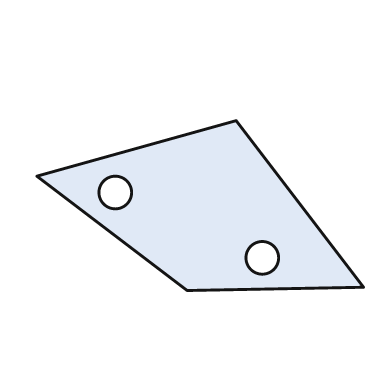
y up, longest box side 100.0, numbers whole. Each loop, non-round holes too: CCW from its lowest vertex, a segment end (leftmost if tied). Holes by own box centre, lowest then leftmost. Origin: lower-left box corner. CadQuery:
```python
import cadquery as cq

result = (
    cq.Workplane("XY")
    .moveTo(46.0, 0.0)
    .lineTo(100.0, 1.0)
    .lineTo(61.0, 52.0)
    .lineTo(0.0, 35.0)
    .close()
    .moveTo(69.0, 10.0)
    .circle(5.0)
    .moveTo(24.0, 30.0)
    .circle(5.0)
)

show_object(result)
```